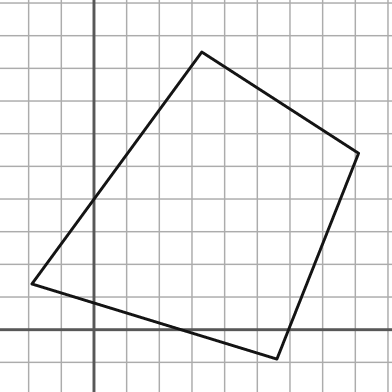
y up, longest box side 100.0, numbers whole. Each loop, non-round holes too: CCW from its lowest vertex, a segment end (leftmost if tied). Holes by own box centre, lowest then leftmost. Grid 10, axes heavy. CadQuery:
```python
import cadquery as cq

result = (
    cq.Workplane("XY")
    .moveTo(56.0, -9.0)
    .lineTo(81.0, 54.0)
    .lineTo(33.0, 85.0)
    .lineTo(-19.0, 14.0)
    .close()
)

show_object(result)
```